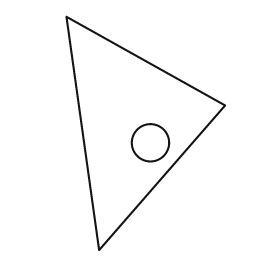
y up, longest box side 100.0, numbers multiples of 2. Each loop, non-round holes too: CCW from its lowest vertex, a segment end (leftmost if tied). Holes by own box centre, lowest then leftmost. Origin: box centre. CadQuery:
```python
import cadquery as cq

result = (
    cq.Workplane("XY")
    .moveTo(-20.0, -50.0)
    .lineTo(34.0, 12.0)
    .lineTo(-34.0, 50.0)
    .close()
    .moveTo(2.0, -4.0)
    .circle(8.0)
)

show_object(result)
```